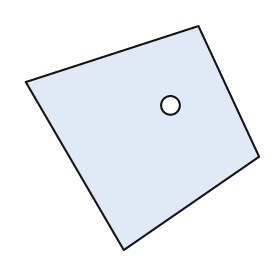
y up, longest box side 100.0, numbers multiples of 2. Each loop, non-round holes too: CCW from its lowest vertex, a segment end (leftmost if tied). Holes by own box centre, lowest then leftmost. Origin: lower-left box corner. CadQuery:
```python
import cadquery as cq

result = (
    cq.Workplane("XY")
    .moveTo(42.0, 0.0)
    .lineTo(100.0, 40.0)
    .lineTo(74.0, 96.0)
    .lineTo(0.0, 72.0)
    .close()
    .moveTo(62.0, 62.0)
    .circle(4.0)
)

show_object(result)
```